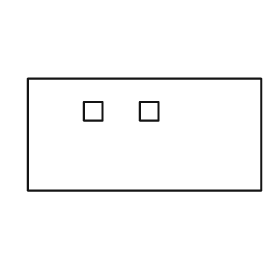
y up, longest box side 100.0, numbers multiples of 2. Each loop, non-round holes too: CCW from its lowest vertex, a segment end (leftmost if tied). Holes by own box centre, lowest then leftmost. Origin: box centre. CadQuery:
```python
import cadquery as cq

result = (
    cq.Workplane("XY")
    .moveTo(-50.0, -24.0)
    .lineTo(50.0, -24.0)
    .lineTo(50.0, 24.0)
    .lineTo(-50.0, 24.0)
    .close()
    .moveTo(-26.0, 6.0)
    .lineTo(-18.0, 6.0)
    .lineTo(-18.0, 14.0)
    .lineTo(-26.0, 14.0)
    .close()
    .moveTo(-2.0, 6.0)
    .lineTo(6.0, 6.0)
    .lineTo(6.0, 14.0)
    .lineTo(-2.0, 14.0)
    .close()
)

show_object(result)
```